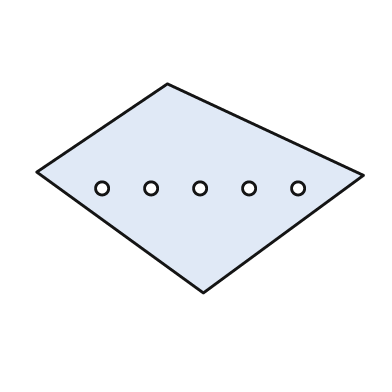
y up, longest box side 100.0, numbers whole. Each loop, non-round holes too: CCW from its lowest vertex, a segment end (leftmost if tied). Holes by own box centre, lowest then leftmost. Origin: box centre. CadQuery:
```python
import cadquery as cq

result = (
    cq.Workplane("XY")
    .moveTo(1.0, -32.0)
    .lineTo(50.0, 4.0)
    .lineTo(-10.0, 32.0)
    .lineTo(-50.0, 5.0)
    .close()
    .moveTo(-30.0, 0.0)
    .circle(2.0)
    .moveTo(-15.0, 0.0)
    .circle(2.0)
    .moveTo(0.0, 0.0)
    .circle(2.0)
    .moveTo(15.0, 0.0)
    .circle(2.0)
    .moveTo(30.0, 0.0)
    .circle(2.0)
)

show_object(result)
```